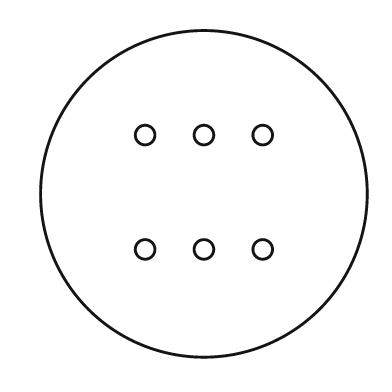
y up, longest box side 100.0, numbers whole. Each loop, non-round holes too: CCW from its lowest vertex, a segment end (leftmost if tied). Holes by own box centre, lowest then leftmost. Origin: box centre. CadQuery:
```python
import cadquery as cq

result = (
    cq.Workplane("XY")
    .moveTo(0.0, 0.0)
    .circle(50.0)
    .moveTo(-18.0, -17.0)
    .circle(3.0)
    .moveTo(0.0, -17.0)
    .circle(3.0)
    .moveTo(18.0, -17.0)
    .circle(3.0)
    .moveTo(-18.0, 18.0)
    .circle(3.0)
    .moveTo(0.0, 18.0)
    .circle(3.0)
    .moveTo(18.0, 18.0)
    .circle(3.0)
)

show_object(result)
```